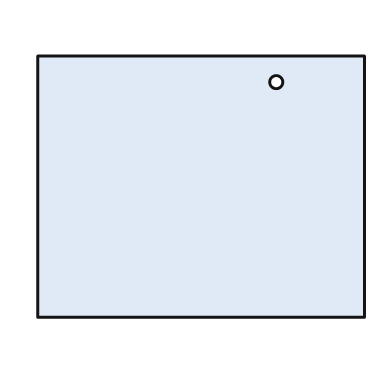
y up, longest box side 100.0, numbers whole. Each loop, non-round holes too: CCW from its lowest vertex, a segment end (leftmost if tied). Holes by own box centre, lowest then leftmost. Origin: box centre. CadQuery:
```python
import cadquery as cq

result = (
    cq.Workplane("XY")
    .moveTo(-50.0, -40.0)
    .lineTo(50.0, -40.0)
    .lineTo(50.0, 40.0)
    .lineTo(-50.0, 40.0)
    .close()
    .moveTo(23.0, 32.0)
    .circle(2.0)
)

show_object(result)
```